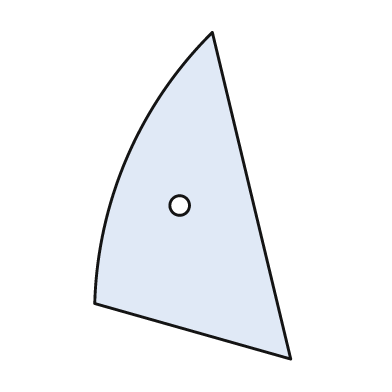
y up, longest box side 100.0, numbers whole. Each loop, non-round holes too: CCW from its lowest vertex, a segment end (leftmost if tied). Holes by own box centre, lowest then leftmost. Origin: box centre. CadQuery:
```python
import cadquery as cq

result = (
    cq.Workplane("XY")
    .moveTo(30.0, -50.0)
    .lineTo(6.0, 50.0)
    .threePointArc((-20.0, 12.0), (-30.0, -33.0))
    .close()
    .moveTo(-4.0, -3.0)
    .circle(3.0)
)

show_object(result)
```